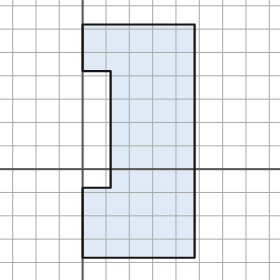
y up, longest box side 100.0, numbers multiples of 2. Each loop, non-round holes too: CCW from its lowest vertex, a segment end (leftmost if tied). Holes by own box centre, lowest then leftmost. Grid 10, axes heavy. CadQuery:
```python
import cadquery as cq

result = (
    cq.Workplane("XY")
    .moveTo(0.0, -38.0)
    .lineTo(48.0, -38.0)
    .lineTo(48.0, 62.0)
    .lineTo(0.0, 62.0)
    .lineTo(0.0, 42.0)
    .lineTo(12.0, 42.0)
    .lineTo(12.0, -8.0)
    .lineTo(0.0, -8.0)
    .close()
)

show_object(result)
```